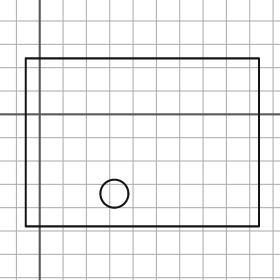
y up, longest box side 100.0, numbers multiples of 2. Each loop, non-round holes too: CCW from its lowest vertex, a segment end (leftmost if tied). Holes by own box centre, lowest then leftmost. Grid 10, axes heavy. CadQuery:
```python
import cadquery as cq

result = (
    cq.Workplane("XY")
    .moveTo(-6.0, -48.0)
    .lineTo(94.0, -48.0)
    .lineTo(94.0, 24.0)
    .lineTo(-6.0, 24.0)
    .close()
    .moveTo(32.0, -34.0)
    .circle(6.0)
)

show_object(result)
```